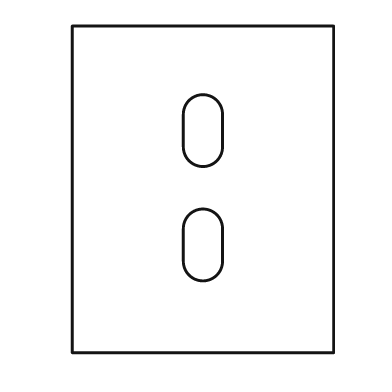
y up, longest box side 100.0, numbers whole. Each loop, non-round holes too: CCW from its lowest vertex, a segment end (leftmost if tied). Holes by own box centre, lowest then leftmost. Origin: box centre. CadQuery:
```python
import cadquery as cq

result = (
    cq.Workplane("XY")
    .moveTo(-40.0, -50.0)
    .lineTo(40.0, -50.0)
    .lineTo(40.0, 50.0)
    .lineTo(-40.0, 50.0)
    .close()
    .moveTo(-6.0, -22.0)
    .threePointArc((0.0, -28.0), (6.0, -22.0))
    .lineTo(6.0, -12.0)
    .threePointArc((0.0, -6.0), (-6.0, -12.0))
    .close()
    .moveTo(-6.0, 13.0)
    .threePointArc((0.0, 7.0), (6.0, 13.0))
    .lineTo(6.0, 23.0)
    .threePointArc((0.0, 29.0), (-6.0, 23.0))
    .close()
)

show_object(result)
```